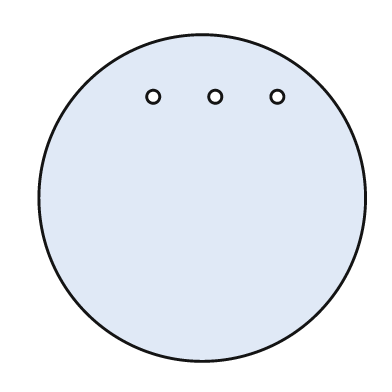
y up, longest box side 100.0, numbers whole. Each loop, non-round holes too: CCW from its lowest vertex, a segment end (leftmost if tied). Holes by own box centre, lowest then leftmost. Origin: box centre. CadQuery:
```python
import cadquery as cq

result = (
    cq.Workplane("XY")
    .moveTo(0.0, 0.0)
    .circle(50.0)
    .moveTo(-15.0, 31.0)
    .circle(2.0)
    .moveTo(4.0, 31.0)
    .circle(2.0)
    .moveTo(23.0, 31.0)
    .circle(2.0)
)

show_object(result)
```